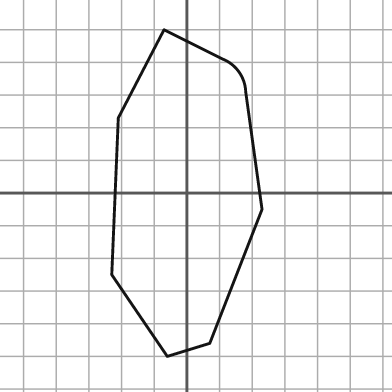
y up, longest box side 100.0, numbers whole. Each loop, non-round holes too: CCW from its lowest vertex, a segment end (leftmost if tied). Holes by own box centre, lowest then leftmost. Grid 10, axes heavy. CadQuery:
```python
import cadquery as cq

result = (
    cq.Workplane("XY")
    .moveTo(-6.0, -50.0)
    .lineTo(7.0, -46.0)
    .lineTo(23.0, -5.0)
    .lineTo(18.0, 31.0)
    .threePointArc((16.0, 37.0), (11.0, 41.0))
    .lineTo(-7.0, 50.0)
    .lineTo(-21.0, 23.0)
    .lineTo(-23.0, -25.0)
    .close()
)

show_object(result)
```